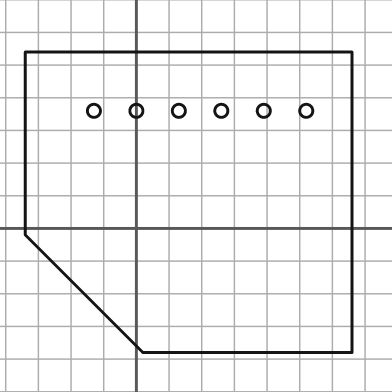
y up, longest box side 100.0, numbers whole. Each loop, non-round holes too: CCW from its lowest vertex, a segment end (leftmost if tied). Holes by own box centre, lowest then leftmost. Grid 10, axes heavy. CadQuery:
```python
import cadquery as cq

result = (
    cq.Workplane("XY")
    .moveTo(2.0, -38.0)
    .lineTo(66.0, -38.0)
    .lineTo(66.0, 54.0)
    .lineTo(-34.0, 54.0)
    .lineTo(-34.0, -2.0)
    .close()
    .moveTo(-13.0, 36.0)
    .circle(2.0)
    .moveTo(0.0, 36.0)
    .circle(2.0)
    .moveTo(13.0, 36.0)
    .circle(2.0)
    .moveTo(26.0, 36.0)
    .circle(2.0)
    .moveTo(39.0, 36.0)
    .circle(2.0)
    .moveTo(52.0, 36.0)
    .circle(2.0)
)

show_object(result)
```